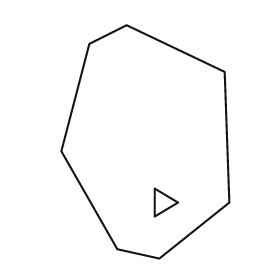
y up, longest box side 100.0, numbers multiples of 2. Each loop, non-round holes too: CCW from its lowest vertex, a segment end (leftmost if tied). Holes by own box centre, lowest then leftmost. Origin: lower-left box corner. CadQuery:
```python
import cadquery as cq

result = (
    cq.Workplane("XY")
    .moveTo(42.0, 0.0)
    .lineTo(72.0, 24.0)
    .lineTo(70.0, 80.0)
    .lineTo(28.0, 100.0)
    .lineTo(12.0, 92.0)
    .lineTo(0.0, 46.0)
    .lineTo(24.0, 4.0)
    .close()
    .moveTo(40.0, 18.0)
    .lineTo(50.0, 24.0)
    .lineTo(40.0, 30.0)
    .close()
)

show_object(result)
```